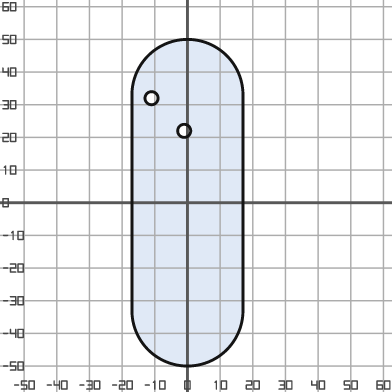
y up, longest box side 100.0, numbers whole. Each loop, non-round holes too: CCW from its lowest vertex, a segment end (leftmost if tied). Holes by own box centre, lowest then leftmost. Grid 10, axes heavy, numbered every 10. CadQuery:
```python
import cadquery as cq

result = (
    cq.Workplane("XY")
    .moveTo(-17.0, -33.0)
    .threePointArc((0.0, -50.0), (17.0, -33.0))
    .lineTo(17.0, 33.0)
    .threePointArc((0.0, 50.0), (-17.0, 33.0))
    .close()
    .moveTo(-1.0, 22.0)
    .circle(2.0)
    .moveTo(-11.0, 32.0)
    .circle(2.0)
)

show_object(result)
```